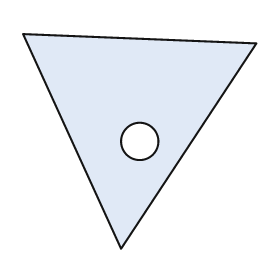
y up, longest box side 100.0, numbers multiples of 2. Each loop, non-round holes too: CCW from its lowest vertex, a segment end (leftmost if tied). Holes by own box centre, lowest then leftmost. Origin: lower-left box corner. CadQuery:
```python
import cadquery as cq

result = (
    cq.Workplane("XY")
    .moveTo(42.0, 0.0)
    .lineTo(100.0, 88.0)
    .lineTo(0.0, 92.0)
    .close()
    .moveTo(50.0, 46.0)
    .circle(8.0)
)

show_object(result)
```